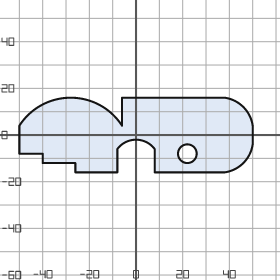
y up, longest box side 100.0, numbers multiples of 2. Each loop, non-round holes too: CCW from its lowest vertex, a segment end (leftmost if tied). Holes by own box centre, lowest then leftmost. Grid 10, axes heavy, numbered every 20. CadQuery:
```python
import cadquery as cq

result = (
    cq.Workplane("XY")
    .moveTo(-26.0, -16.0)
    .lineTo(-8.0, -16.0)
    .lineTo(-8.0, -6.0)
    .threePointArc((0.0, -2.0), (8.0, -6.0))
    .lineTo(8.0, -16.0)
    .lineTo(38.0, -16.0)
    .threePointArc((46.0, -12.0), (50.0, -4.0))
    .lineTo(50.0, 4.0)
    .threePointArc((46.0, 12.0), (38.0, 16.0))
    .lineTo(-6.0, 16.0)
    .lineTo(-6.0, 4.0)
    .threePointArc((-28.0, 16.0), (-50.0, 4.0))
    .lineTo(-50.0, -8.0)
    .lineTo(-40.0, -8.0)
    .lineTo(-40.0, -12.0)
    .lineTo(-26.0, -12.0)
    .close()
    .moveTo(22.0, -8.0)
    .circle(4.0)
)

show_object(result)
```